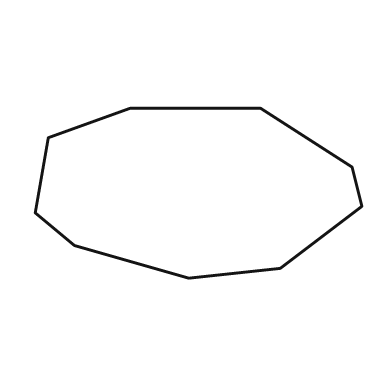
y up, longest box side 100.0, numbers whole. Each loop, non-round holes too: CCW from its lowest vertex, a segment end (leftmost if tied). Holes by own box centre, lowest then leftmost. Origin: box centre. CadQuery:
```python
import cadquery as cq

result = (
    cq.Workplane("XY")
    .moveTo(-3.0, -26.0)
    .lineTo(25.0, -23.0)
    .lineTo(50.0, -4.0)
    .lineTo(47.0, 8.0)
    .lineTo(19.0, 26.0)
    .lineTo(-21.0, 26.0)
    .lineTo(-46.0, 17.0)
    .lineTo(-50.0, -6.0)
    .lineTo(-38.0, -16.0)
    .close()
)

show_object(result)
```